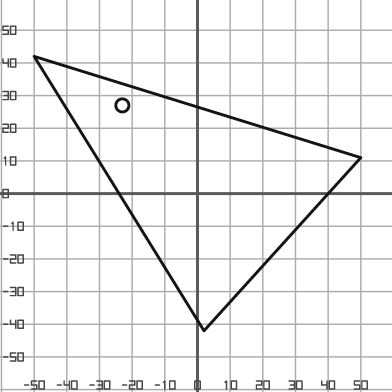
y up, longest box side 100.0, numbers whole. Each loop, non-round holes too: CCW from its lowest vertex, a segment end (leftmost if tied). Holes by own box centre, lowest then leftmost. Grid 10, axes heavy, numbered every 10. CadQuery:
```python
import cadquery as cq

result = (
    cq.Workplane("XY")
    .moveTo(2.0, -42.0)
    .lineTo(50.0, 11.0)
    .lineTo(-50.0, 42.0)
    .close()
    .moveTo(-23.0, 27.0)
    .circle(2.0)
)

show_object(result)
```